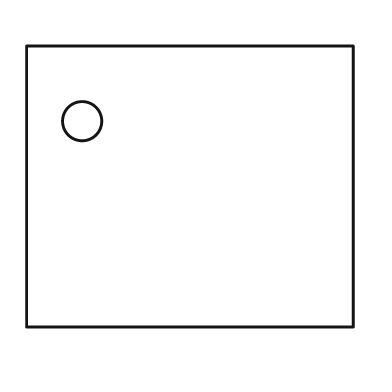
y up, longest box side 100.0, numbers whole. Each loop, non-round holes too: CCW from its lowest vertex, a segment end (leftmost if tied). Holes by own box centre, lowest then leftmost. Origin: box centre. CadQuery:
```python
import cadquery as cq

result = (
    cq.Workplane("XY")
    .moveTo(-50.0, -43.0)
    .lineTo(50.0, -43.0)
    .lineTo(50.0, 43.0)
    .lineTo(-50.0, 43.0)
    .close()
    .moveTo(-33.0, 20.0)
    .circle(6.0)
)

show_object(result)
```